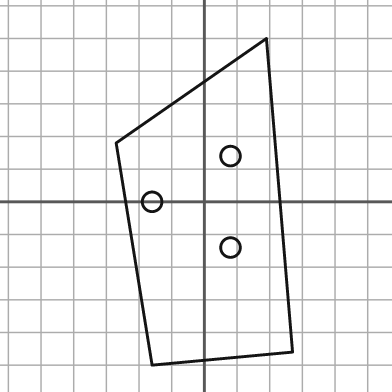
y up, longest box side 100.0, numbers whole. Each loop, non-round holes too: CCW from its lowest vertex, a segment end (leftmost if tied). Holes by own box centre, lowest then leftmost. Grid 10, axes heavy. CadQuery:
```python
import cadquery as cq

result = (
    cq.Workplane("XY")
    .moveTo(-16.0, -50.0)
    .lineTo(27.0, -46.0)
    .lineTo(19.0, 50.0)
    .lineTo(-27.0, 18.0)
    .close()
    .moveTo(8.0, -14.0)
    .circle(3.0)
    .moveTo(-16.0, 0.0)
    .circle(3.0)
    .moveTo(8.0, 14.0)
    .circle(3.0)
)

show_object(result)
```